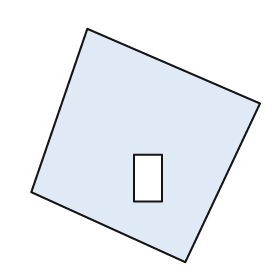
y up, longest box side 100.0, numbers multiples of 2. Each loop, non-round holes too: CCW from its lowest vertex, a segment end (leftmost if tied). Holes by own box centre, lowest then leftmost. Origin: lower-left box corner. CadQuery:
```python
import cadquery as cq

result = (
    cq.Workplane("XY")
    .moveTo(66.0, 0.0)
    .lineTo(98.0, 68.0)
    .lineTo(24.0, 100.0)
    .lineTo(0.0, 30.0)
    .close()
    .moveTo(44.0, 26.0)
    .lineTo(56.0, 26.0)
    .lineTo(56.0, 46.0)
    .lineTo(44.0, 46.0)
    .close()
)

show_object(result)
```